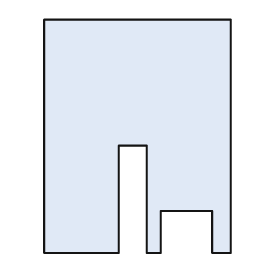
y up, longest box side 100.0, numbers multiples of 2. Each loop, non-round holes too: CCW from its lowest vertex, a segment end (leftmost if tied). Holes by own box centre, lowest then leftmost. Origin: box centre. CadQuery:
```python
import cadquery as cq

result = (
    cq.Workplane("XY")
    .moveTo(-40.0, -50.0)
    .lineTo(-8.0, -50.0)
    .lineTo(-8.0, -4.0)
    .lineTo(4.0, -4.0)
    .lineTo(4.0, -50.0)
    .lineTo(10.0, -50.0)
    .lineTo(10.0, -32.0)
    .lineTo(32.0, -32.0)
    .lineTo(32.0, -50.0)
    .lineTo(40.0, -50.0)
    .lineTo(40.0, 50.0)
    .lineTo(-40.0, 50.0)
    .close()
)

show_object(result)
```